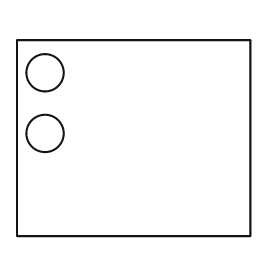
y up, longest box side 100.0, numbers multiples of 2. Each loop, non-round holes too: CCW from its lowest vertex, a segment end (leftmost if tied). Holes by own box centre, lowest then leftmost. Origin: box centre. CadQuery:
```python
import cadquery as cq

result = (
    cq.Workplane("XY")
    .moveTo(-50.0, -42.0)
    .lineTo(50.0, -42.0)
    .lineTo(50.0, 42.0)
    .lineTo(-50.0, 42.0)
    .close()
    .moveTo(-38.0, 2.0)
    .circle(8.0)
    .moveTo(-38.0, 28.0)
    .circle(8.0)
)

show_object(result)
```